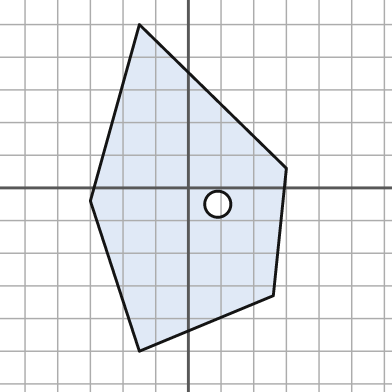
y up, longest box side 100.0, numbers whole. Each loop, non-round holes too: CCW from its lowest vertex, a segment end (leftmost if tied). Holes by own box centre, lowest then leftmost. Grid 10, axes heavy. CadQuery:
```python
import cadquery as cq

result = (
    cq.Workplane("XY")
    .moveTo(-15.0, -50.0)
    .lineTo(26.0, -33.0)
    .lineTo(30.0, 6.0)
    .lineTo(-15.0, 50.0)
    .lineTo(-30.0, -4.0)
    .close()
    .moveTo(9.0, -5.0)
    .circle(4.0)
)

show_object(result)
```